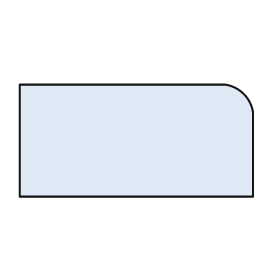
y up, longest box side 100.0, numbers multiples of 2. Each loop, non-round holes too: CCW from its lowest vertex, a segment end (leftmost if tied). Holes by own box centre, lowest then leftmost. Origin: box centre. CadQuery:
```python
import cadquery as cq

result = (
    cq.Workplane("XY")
    .moveTo(-50.0, -24.0)
    .lineTo(50.0, -24.0)
    .lineTo(50.0, 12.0)
    .threePointArc((46.0, 20.0), (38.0, 24.0))
    .lineTo(-50.0, 24.0)
    .close()
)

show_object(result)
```